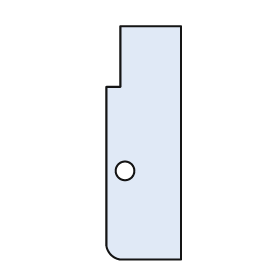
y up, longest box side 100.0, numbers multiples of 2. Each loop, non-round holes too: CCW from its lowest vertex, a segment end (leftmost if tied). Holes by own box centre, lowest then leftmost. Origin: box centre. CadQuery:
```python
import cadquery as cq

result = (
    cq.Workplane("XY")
    .moveTo(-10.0, -50.0)
    .lineTo(16.0, -50.0)
    .lineTo(16.0, 50.0)
    .lineTo(-10.0, 50.0)
    .lineTo(-10.0, 24.0)
    .lineTo(-16.0, 24.0)
    .lineTo(-16.0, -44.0)
    .threePointArc((-14.0, -48.0), (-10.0, -50.0))
    .close()
    .moveTo(-8.0, -12.0)
    .circle(4.0)
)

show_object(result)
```